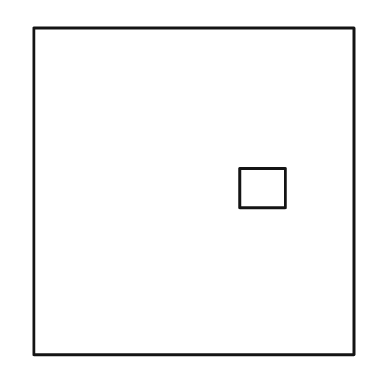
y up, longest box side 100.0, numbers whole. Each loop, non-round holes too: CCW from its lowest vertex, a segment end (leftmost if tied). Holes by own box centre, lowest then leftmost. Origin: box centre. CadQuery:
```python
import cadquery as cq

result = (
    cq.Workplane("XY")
    .moveTo(-49.0, -50.0)
    .lineTo(49.0, -50.0)
    .lineTo(49.0, 50.0)
    .lineTo(-49.0, 50.0)
    .close()
    .moveTo(14.0, -5.0)
    .lineTo(28.0, -5.0)
    .lineTo(28.0, 7.0)
    .lineTo(14.0, 7.0)
    .close()
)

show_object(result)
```